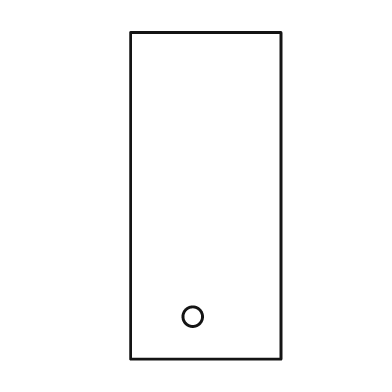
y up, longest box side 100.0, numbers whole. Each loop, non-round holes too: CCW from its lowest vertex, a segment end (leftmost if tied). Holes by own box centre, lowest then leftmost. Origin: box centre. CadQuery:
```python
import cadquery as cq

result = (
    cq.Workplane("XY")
    .moveTo(-23.0, -50.0)
    .lineTo(23.0, -50.0)
    .lineTo(23.0, 50.0)
    .lineTo(-23.0, 50.0)
    .close()
    .moveTo(-4.0, -37.0)
    .circle(3.0)
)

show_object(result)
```